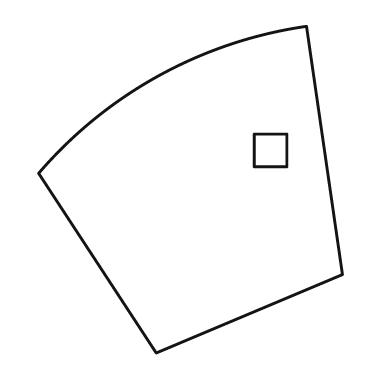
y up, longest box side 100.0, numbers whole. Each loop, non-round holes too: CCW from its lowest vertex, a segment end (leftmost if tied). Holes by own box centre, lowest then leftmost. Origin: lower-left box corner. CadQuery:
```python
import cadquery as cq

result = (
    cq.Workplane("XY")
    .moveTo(36.0, 0.0)
    .lineTo(93.0, 24.0)
    .lineTo(82.0, 100.0)
    .threePointArc((37.0, 85.0), (0.0, 55.0))
    .close()
    .moveTo(66.0, 57.0)
    .lineTo(76.0, 57.0)
    .lineTo(76.0, 67.0)
    .lineTo(66.0, 67.0)
    .close()
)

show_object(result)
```